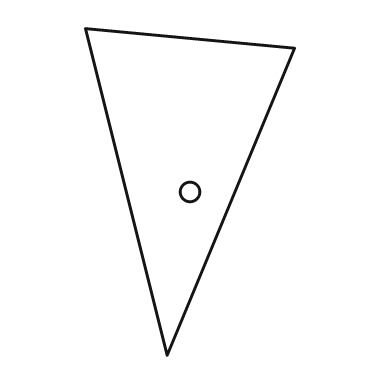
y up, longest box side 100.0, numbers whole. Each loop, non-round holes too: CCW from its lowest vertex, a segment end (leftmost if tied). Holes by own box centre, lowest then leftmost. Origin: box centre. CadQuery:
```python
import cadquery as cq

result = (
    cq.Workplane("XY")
    .moveTo(-7.0, -50.0)
    .lineTo(32.0, 44.0)
    .lineTo(-32.0, 50.0)
    .close()
    .moveTo(0.0, 0.0)
    .circle(3.0)
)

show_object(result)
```